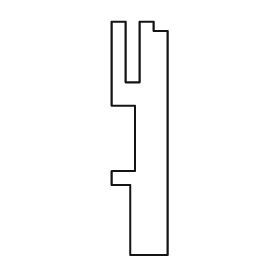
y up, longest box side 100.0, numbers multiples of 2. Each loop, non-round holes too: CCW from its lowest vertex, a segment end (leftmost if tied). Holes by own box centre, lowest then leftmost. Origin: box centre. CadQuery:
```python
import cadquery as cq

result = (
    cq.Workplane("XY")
    .moveTo(-4.0, -50.0)
    .lineTo(12.0, -50.0)
    .lineTo(12.0, 46.0)
    .lineTo(6.0, 46.0)
    .lineTo(6.0, 50.0)
    .lineTo(0.0, 50.0)
    .lineTo(0.0, 24.0)
    .lineTo(-6.0, 24.0)
    .lineTo(-6.0, 50.0)
    .lineTo(-12.0, 50.0)
    .lineTo(-12.0, 14.0)
    .lineTo(-2.0, 14.0)
    .lineTo(-2.0, -14.0)
    .lineTo(-12.0, -14.0)
    .lineTo(-12.0, -20.0)
    .lineTo(-4.0, -20.0)
    .close()
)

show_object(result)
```